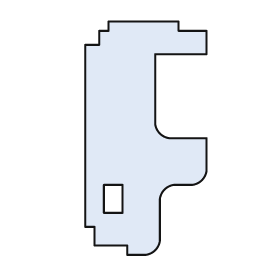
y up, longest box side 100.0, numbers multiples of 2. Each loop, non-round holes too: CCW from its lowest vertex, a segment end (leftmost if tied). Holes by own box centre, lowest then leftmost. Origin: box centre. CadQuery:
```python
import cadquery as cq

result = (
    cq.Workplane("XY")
    .moveTo(-8.0, -50.0)
    .lineTo(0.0, -50.0)
    .threePointArc((4.0, -48.0), (6.0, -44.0))
    .lineTo(6.0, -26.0)
    .threePointArc((8.0, -22.0), (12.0, -20.0))
    .lineTo(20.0, -20.0)
    .threePointArc((24.0, -18.0), (26.0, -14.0))
    .lineTo(26.0, 0.0)
    .lineTo(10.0, 0.0)
    .threePointArc((6.0, 2.0), (4.0, 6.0))
    .lineTo(4.0, 36.0)
    .lineTo(26.0, 36.0)
    .lineTo(26.0, 46.0)
    .lineTo(14.0, 46.0)
    .lineTo(14.0, 50.0)
    .lineTo(-16.0, 50.0)
    .lineTo(-16.0, 46.0)
    .lineTo(-20.0, 46.0)
    .lineTo(-20.0, 40.0)
    .lineTo(-26.0, 40.0)
    .lineTo(-26.0, -38.0)
    .lineTo(-22.0, -38.0)
    .lineTo(-22.0, -46.0)
    .lineTo(-8.0, -46.0)
    .close()
    .moveTo(-18.0, -32.0)
    .lineTo(-10.0, -32.0)
    .lineTo(-10.0, -20.0)
    .lineTo(-18.0, -20.0)
    .close()
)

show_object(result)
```